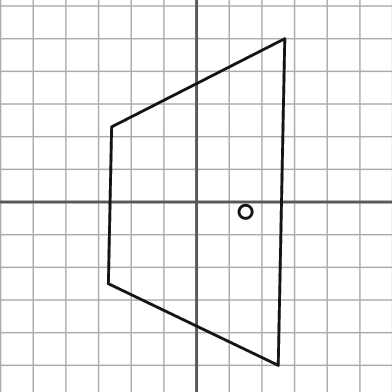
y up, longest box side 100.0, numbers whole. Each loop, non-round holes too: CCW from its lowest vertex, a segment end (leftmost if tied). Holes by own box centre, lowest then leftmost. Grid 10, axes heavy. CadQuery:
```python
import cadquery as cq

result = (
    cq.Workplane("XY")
    .moveTo(25.0, -50.0)
    .lineTo(27.0, 50.0)
    .lineTo(-26.0, 23.0)
    .lineTo(-27.0, -25.0)
    .close()
    .moveTo(15.0, -3.0)
    .circle(2.0)
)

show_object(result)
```